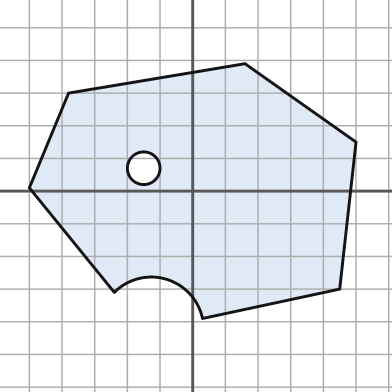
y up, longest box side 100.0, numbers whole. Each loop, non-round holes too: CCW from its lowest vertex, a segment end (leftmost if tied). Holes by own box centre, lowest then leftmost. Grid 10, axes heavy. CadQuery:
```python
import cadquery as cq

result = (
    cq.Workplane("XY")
    .moveTo(3.0, -39.0)
    .lineTo(45.0, -30.0)
    .lineTo(50.0, 15.0)
    .lineTo(16.0, 39.0)
    .lineTo(-38.0, 30.0)
    .lineTo(-50.0, 1.0)
    .lineTo(-24.0, -31.0)
    .threePointArc((-8.0, -27.0), (3.0, -39.0))
    .close()
    .moveTo(-15.0, 7.0)
    .circle(5.0)
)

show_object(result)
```